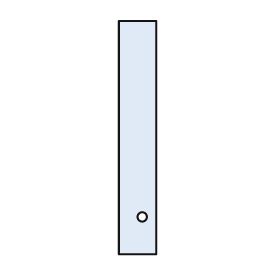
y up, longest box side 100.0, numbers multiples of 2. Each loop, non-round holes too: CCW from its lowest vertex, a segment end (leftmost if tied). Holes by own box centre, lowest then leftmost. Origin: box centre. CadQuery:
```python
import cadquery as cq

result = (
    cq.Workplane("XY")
    .moveTo(-8.0, -50.0)
    .lineTo(8.0, -50.0)
    .lineTo(8.0, 50.0)
    .lineTo(-8.0, 50.0)
    .close()
    .moveTo(2.0, -34.0)
    .circle(2.0)
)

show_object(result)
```